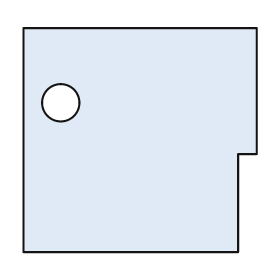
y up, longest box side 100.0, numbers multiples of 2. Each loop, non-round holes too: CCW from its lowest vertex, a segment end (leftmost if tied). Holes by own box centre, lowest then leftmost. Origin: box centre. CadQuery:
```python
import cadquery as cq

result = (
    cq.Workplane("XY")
    .moveTo(-50.0, -48.0)
    .lineTo(42.0, -48.0)
    .lineTo(42.0, -6.0)
    .lineTo(50.0, -6.0)
    .lineTo(50.0, 48.0)
    .lineTo(-50.0, 48.0)
    .close()
    .moveTo(-34.0, 16.0)
    .circle(8.0)
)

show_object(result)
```